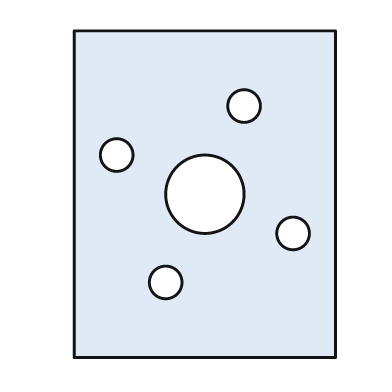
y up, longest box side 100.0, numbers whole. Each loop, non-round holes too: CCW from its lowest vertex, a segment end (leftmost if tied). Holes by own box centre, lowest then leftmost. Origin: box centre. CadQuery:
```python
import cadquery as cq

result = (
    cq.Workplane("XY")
    .moveTo(-40.0, -50.0)
    .lineTo(40.0, -50.0)
    .lineTo(40.0, 50.0)
    .lineTo(-40.0, 50.0)
    .close()
    .moveTo(-12.0, -27.0)
    .circle(5.0)
    .moveTo(27.0, -12.0)
    .circle(5.0)
    .moveTo(0.0, 0.0)
    .circle(12.0)
    .moveTo(-27.0, 12.0)
    .circle(5.0)
    .moveTo(12.0, 27.0)
    .circle(5.0)
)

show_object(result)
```